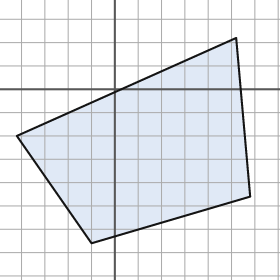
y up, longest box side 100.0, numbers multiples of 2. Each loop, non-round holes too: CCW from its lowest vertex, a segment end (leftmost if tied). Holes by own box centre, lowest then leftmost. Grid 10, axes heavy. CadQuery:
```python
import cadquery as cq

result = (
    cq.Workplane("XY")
    .moveTo(-10.0, -66.0)
    .lineTo(58.0, -46.0)
    .lineTo(52.0, 22.0)
    .lineTo(-42.0, -20.0)
    .close()
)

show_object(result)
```